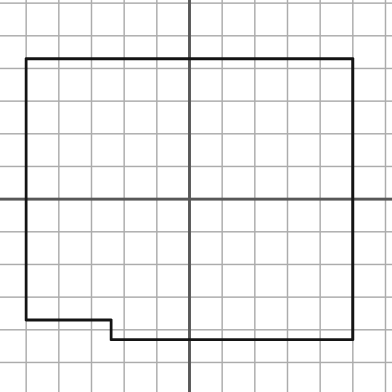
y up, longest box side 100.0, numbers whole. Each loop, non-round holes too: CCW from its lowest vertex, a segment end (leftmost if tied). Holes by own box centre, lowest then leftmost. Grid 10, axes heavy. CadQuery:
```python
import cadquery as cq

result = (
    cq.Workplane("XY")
    .moveTo(-24.0, -43.0)
    .lineTo(50.0, -43.0)
    .lineTo(50.0, 43.0)
    .lineTo(-50.0, 43.0)
    .lineTo(-50.0, -37.0)
    .lineTo(-24.0, -37.0)
    .close()
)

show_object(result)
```